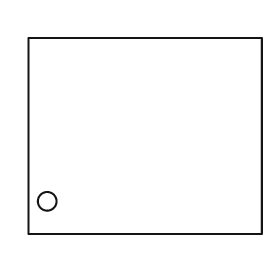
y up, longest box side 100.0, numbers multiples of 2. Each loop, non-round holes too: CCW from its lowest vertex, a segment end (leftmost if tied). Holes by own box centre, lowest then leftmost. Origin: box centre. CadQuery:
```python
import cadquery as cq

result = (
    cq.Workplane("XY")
    .moveTo(-50.0, -42.0)
    .lineTo(50.0, -42.0)
    .lineTo(50.0, 42.0)
    .lineTo(-50.0, 42.0)
    .close()
    .moveTo(-42.0, -28.0)
    .circle(4.0)
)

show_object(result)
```